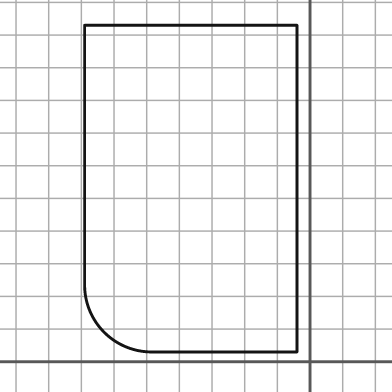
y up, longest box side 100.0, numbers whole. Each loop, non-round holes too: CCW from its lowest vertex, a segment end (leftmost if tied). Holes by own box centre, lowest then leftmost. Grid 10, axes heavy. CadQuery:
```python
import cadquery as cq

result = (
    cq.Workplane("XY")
    .moveTo(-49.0, 3.0)
    .lineTo(-4.0, 3.0)
    .lineTo(-4.0, 103.0)
    .lineTo(-69.0, 103.0)
    .lineTo(-69.0, 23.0)
    .threePointArc((-63.0, 9.0), (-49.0, 3.0))
    .close()
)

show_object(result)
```